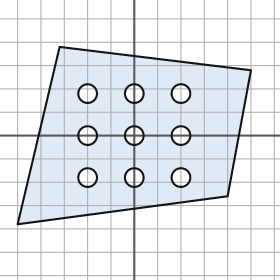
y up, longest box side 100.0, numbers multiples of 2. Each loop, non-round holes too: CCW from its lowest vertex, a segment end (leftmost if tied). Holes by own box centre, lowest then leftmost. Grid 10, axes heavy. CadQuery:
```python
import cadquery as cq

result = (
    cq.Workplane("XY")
    .moveTo(-50.0, -38.0)
    .lineTo(40.0, -26.0)
    .lineTo(50.0, 28.0)
    .lineTo(-32.0, 38.0)
    .close()
    .moveTo(-20.0, -18.0)
    .circle(4.0)
    .moveTo(0.0, -18.0)
    .circle(4.0)
    .moveTo(20.0, -18.0)
    .circle(4.0)
    .moveTo(-20.0, 0.0)
    .circle(4.0)
    .moveTo(0.0, 0.0)
    .circle(4.0)
    .moveTo(20.0, 0.0)
    .circle(4.0)
    .moveTo(-20.0, 18.0)
    .circle(4.0)
    .moveTo(0.0, 18.0)
    .circle(4.0)
    .moveTo(20.0, 18.0)
    .circle(4.0)
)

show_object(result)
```